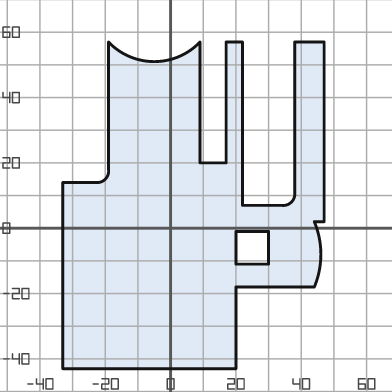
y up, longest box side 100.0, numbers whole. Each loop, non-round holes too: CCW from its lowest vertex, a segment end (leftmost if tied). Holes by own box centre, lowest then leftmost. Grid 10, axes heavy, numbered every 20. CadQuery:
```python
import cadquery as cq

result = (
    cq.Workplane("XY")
    .moveTo(-33.0, -43.0)
    .lineTo(20.0, -43.0)
    .lineTo(20.0, -18.0)
    .lineTo(44.0, -18.0)
    .threePointArc((46.0, -8.0), (44.0, 2.0))
    .lineTo(47.0, 2.0)
    .lineTo(47.0, 57.0)
    .lineTo(38.0, 57.0)
    .lineTo(38.0, 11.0)
    .threePointArc((37.0, 8.0), (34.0, 7.0))
    .lineTo(22.0, 7.0)
    .lineTo(22.0, 57.0)
    .lineTo(17.0, 57.0)
    .lineTo(17.0, 20.0)
    .lineTo(9.0, 20.0)
    .lineTo(9.0, 57.0)
    .threePointArc((-5.0, 51.0), (-19.0, 57.0))
    .lineTo(-19.0, 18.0)
    .threePointArc((-20.0, 15.0), (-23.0, 14.0))
    .lineTo(-33.0, 14.0)
    .close()
    .moveTo(20.0, -11.0)
    .lineTo(30.0, -11.0)
    .lineTo(30.0, -1.0)
    .lineTo(20.0, -1.0)
    .close()
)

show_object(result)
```